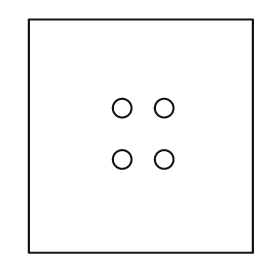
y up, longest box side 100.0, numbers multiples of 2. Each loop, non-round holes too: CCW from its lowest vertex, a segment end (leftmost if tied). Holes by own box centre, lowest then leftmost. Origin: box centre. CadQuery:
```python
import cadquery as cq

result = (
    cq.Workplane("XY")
    .moveTo(-48.0, -50.0)
    .lineTo(48.0, -50.0)
    .lineTo(48.0, 50.0)
    .lineTo(-48.0, 50.0)
    .close()
    .moveTo(-8.0, -10.0)
    .circle(4.0)
    .moveTo(10.0, -10.0)
    .circle(4.0)
    .moveTo(-8.0, 12.0)
    .circle(4.0)
    .moveTo(10.0, 12.0)
    .circle(4.0)
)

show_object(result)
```